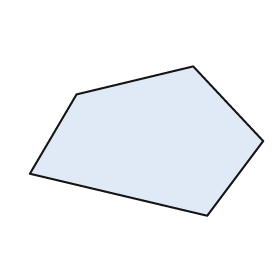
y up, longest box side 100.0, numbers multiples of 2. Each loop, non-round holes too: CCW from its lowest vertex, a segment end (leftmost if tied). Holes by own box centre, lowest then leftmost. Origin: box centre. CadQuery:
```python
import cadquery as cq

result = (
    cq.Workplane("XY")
    .moveTo(26.0, -32.0)
    .lineTo(50.0, 0.0)
    .lineTo(20.0, 32.0)
    .lineTo(-30.0, 20.0)
    .lineTo(-50.0, -14.0)
    .close()
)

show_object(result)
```